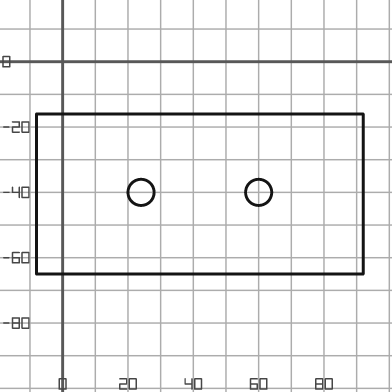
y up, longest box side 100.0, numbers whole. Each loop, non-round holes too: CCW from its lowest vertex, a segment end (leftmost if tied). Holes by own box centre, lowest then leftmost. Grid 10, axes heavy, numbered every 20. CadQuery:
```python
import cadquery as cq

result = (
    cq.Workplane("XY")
    .moveTo(-8.0, -65.0)
    .lineTo(92.0, -65.0)
    .lineTo(92.0, -16.0)
    .lineTo(-8.0, -16.0)
    .close()
    .moveTo(24.0, -40.0)
    .circle(4.0)
    .moveTo(60.0, -40.0)
    .circle(4.0)
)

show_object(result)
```